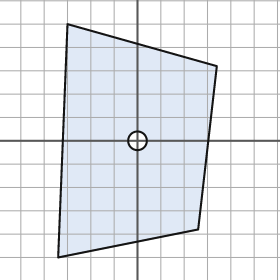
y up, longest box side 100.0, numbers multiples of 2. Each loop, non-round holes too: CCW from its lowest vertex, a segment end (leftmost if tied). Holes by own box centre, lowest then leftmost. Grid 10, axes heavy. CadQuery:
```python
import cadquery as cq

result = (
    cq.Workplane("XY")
    .moveTo(-34.0, -50.0)
    .lineTo(26.0, -38.0)
    .lineTo(34.0, 32.0)
    .lineTo(-30.0, 50.0)
    .close()
    .moveTo(0.0, 0.0)
    .circle(4.0)
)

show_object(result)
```